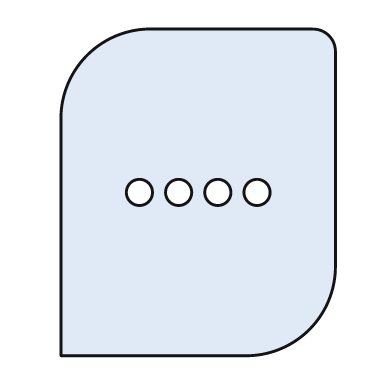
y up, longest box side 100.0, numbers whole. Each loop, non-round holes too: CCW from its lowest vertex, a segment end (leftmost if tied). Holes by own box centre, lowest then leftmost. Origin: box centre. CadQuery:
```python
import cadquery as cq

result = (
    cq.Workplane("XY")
    .moveTo(-42.0, -50.0)
    .lineTo(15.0, -50.0)
    .threePointArc((34.0, -42.0), (42.0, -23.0))
    .lineTo(42.0, 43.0)
    .threePointArc((40.0, 48.0), (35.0, 50.0))
    .lineTo(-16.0, 50.0)
    .threePointArc((-34.0, 42.0), (-42.0, 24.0))
    .close()
    .moveTo(-18.0, 0.0)
    .circle(4.0)
    .moveTo(-6.0, 0.0)
    .circle(4.0)
    .moveTo(6.0, 0.0)
    .circle(4.0)
    .moveTo(18.0, 0.0)
    .circle(4.0)
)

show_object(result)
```